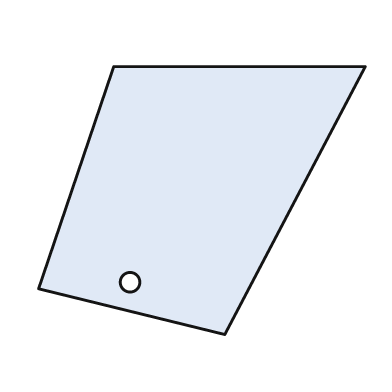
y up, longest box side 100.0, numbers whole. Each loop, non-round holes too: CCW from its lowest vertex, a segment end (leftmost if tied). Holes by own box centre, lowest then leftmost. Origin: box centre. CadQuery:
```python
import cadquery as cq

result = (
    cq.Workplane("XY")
    .moveTo(7.0, -41.0)
    .lineTo(50.0, 41.0)
    .lineTo(-27.0, 41.0)
    .lineTo(-50.0, -27.0)
    .close()
    .moveTo(-22.0, -25.0)
    .circle(3.0)
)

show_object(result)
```